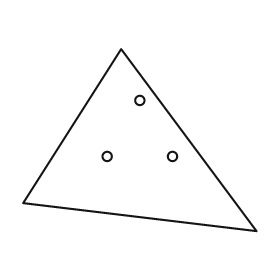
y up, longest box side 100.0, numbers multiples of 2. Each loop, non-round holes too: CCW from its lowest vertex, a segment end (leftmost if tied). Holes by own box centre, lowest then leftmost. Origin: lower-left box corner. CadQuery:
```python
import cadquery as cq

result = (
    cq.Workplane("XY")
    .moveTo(100.0, 0.0)
    .lineTo(42.0, 78.0)
    .lineTo(0.0, 12.0)
    .close()
    .moveTo(36.0, 32.0)
    .circle(2.0)
    .moveTo(64.0, 32.0)
    .circle(2.0)
    .moveTo(50.0, 56.0)
    .circle(2.0)
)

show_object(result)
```